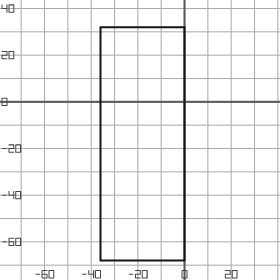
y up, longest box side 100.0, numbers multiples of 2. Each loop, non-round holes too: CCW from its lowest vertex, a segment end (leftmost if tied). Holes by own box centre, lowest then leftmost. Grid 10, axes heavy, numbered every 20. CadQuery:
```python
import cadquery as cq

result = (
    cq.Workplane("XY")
    .moveTo(-36.0, -68.0)
    .lineTo(0.0, -68.0)
    .lineTo(0.0, 32.0)
    .lineTo(-36.0, 32.0)
    .close()
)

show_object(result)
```